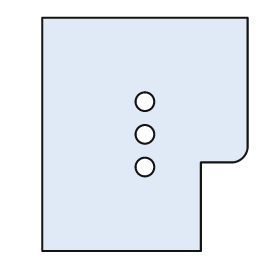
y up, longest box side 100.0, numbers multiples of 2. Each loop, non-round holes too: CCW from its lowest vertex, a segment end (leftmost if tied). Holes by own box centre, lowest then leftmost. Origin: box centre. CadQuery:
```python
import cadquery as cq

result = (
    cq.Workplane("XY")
    .moveTo(-44.0, -50.0)
    .lineTo(24.0, -50.0)
    .lineTo(24.0, -12.0)
    .lineTo(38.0, -12.0)
    .threePointArc((42.0, -10.0), (44.0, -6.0))
    .lineTo(44.0, 50.0)
    .lineTo(-44.0, 50.0)
    .close()
    .moveTo(0.0, -14.0)
    .circle(4.0)
    .moveTo(0.0, 0.0)
    .circle(4.0)
    .moveTo(0.0, 14.0)
    .circle(4.0)
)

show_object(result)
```